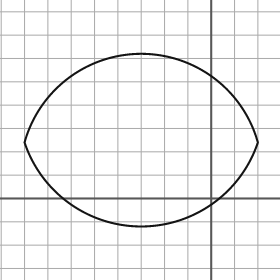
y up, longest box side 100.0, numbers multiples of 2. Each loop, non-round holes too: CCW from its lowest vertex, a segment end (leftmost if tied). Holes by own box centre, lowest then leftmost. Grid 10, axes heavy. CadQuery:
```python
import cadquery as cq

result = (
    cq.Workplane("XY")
    .moveTo(-80.0, 24.0)
    .threePointArc((-30.0, -12.0), (20.0, 24.0))
    .threePointArc((-30.0, 62.0), (-80.0, 24.0))
    .close()
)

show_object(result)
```